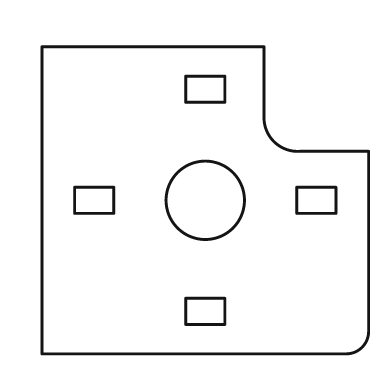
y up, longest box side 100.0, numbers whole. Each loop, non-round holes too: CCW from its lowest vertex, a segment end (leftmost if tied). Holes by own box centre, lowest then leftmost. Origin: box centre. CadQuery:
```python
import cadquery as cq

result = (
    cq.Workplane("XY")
    .moveTo(-50.0, -47.0)
    .lineTo(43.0, -47.0)
    .threePointArc((48.0, -45.0), (50.0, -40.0))
    .lineTo(50.0, 15.0)
    .lineTo(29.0, 15.0)
    .threePointArc((21.0, 18.0), (18.0, 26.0))
    .lineTo(18.0, 47.0)
    .lineTo(-50.0, 47.0)
    .close()
    .moveTo(-6.0, -38.0)
    .lineTo(6.0, -38.0)
    .lineTo(6.0, -30.0)
    .lineTo(-6.0, -30.0)
    .close()
    .moveTo(-40.0, -4.0)
    .lineTo(-28.0, -4.0)
    .lineTo(-28.0, 4.0)
    .lineTo(-40.0, 4.0)
    .close()
    .moveTo(0.0, 0.0)
    .circle(12.0)
    .moveTo(28.0, -4.0)
    .lineTo(40.0, -4.0)
    .lineTo(40.0, 4.0)
    .lineTo(28.0, 4.0)
    .close()
    .moveTo(-6.0, 30.0)
    .lineTo(6.0, 30.0)
    .lineTo(6.0, 38.0)
    .lineTo(-6.0, 38.0)
    .close()
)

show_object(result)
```